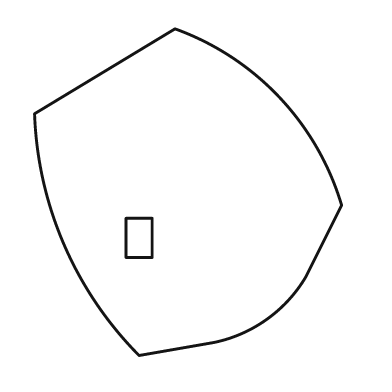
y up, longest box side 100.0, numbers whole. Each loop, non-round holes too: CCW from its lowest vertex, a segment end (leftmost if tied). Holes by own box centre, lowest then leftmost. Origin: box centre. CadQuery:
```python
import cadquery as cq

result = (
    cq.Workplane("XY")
    .moveTo(-15.0, -50.0)
    .lineTo(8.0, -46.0)
    .threePointArc((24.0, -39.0), (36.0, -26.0))
    .lineTo(47.0, -4.0)
    .threePointArc((28.0, 29.0), (-4.0, 50.0))
    .lineTo(-47.0, 24.0)
    .threePointArc((-38.0, -16.0), (-15.0, -50.0))
    .close()
    .moveTo(-19.0, -20.0)
    .lineTo(-11.0, -20.0)
    .lineTo(-11.0, -8.0)
    .lineTo(-19.0, -8.0)
    .close()
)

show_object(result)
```